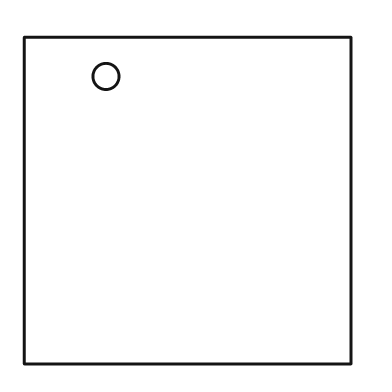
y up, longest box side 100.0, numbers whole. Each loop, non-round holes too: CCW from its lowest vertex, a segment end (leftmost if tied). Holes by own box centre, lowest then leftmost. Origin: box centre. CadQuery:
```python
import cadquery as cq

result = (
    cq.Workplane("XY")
    .moveTo(-50.0, -50.0)
    .lineTo(50.0, -50.0)
    .lineTo(50.0, 50.0)
    .lineTo(-50.0, 50.0)
    .close()
    .moveTo(-25.0, 38.0)
    .circle(4.0)
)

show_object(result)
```